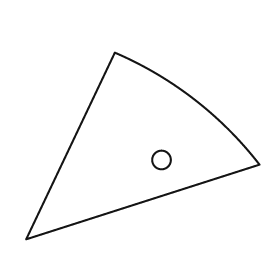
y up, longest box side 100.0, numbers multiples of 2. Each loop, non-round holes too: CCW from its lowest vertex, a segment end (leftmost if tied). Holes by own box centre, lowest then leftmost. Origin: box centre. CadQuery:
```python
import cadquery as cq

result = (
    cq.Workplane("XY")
    .moveTo(-50.0, -40.0)
    .lineTo(50.0, -8.0)
    .threePointArc((22.0, 20.0), (-12.0, 40.0))
    .close()
    .moveTo(8.0, -6.0)
    .circle(4.0)
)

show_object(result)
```